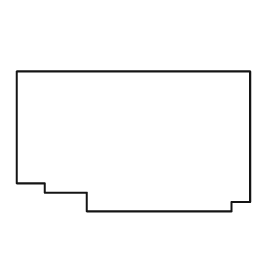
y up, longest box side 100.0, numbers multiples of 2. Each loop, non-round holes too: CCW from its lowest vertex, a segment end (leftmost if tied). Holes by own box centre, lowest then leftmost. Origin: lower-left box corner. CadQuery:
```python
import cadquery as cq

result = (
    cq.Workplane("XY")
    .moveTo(30.0, 0.0)
    .lineTo(92.0, 0.0)
    .lineTo(92.0, 4.0)
    .lineTo(100.0, 4.0)
    .lineTo(100.0, 60.0)
    .lineTo(0.0, 60.0)
    .lineTo(0.0, 12.0)
    .lineTo(12.0, 12.0)
    .lineTo(12.0, 8.0)
    .lineTo(30.0, 8.0)
    .close()
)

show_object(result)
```